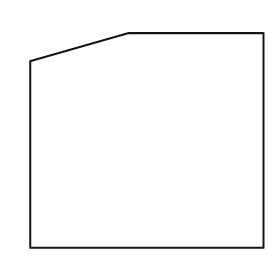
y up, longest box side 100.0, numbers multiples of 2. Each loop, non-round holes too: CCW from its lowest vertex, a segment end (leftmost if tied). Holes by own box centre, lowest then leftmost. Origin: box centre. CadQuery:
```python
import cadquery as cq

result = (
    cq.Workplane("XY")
    .moveTo(-50.0, -46.0)
    .lineTo(50.0, -46.0)
    .lineTo(50.0, 46.0)
    .lineTo(-8.0, 46.0)
    .lineTo(-50.0, 34.0)
    .close()
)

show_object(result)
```